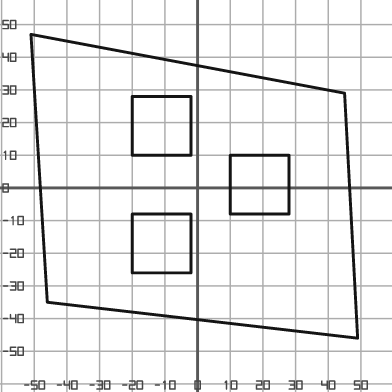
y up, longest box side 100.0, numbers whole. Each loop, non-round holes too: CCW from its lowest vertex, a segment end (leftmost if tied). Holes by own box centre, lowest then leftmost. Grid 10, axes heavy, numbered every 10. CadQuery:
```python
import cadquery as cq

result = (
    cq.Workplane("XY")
    .moveTo(49.0, -46.0)
    .lineTo(45.0, 29.0)
    .lineTo(-51.0, 47.0)
    .lineTo(-46.0, -35.0)
    .close()
    .moveTo(-20.0, -26.0)
    .lineTo(-2.0, -26.0)
    .lineTo(-2.0, -8.0)
    .lineTo(-20.0, -8.0)
    .close()
    .moveTo(10.0, -8.0)
    .lineTo(28.0, -8.0)
    .lineTo(28.0, 10.0)
    .lineTo(10.0, 10.0)
    .close()
    .moveTo(-20.0, 10.0)
    .lineTo(-2.0, 10.0)
    .lineTo(-2.0, 28.0)
    .lineTo(-20.0, 28.0)
    .close()
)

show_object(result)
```